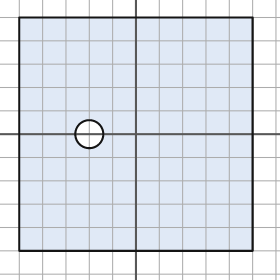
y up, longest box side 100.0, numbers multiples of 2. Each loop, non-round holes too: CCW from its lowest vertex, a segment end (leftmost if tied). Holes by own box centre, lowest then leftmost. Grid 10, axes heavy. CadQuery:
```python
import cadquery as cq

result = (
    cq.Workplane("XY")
    .moveTo(-50.0, -50.0)
    .lineTo(50.0, -50.0)
    .lineTo(50.0, 50.0)
    .lineTo(-50.0, 50.0)
    .close()
    .moveTo(-20.0, 0.0)
    .circle(6.0)
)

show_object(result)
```